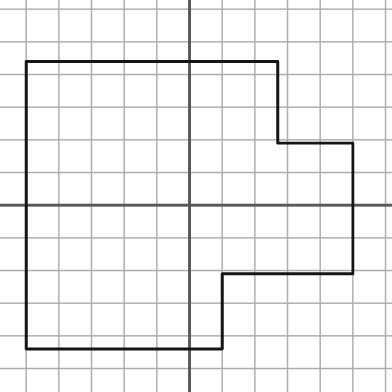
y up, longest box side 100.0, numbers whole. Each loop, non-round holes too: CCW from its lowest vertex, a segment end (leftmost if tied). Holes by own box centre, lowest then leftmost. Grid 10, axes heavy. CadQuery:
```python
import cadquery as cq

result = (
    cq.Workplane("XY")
    .moveTo(-50.0, -44.0)
    .lineTo(10.0, -44.0)
    .lineTo(10.0, -21.0)
    .lineTo(50.0, -21.0)
    .lineTo(50.0, 19.0)
    .lineTo(27.0, 19.0)
    .lineTo(27.0, 44.0)
    .lineTo(-50.0, 44.0)
    .close()
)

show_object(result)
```